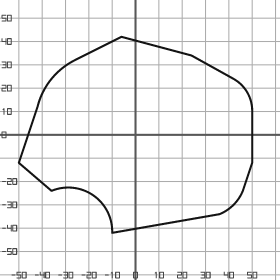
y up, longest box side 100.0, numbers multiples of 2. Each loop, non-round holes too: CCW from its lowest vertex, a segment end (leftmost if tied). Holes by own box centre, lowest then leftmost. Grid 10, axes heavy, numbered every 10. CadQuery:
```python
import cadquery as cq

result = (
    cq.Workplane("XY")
    .moveTo(-10.0, -42.0)
    .lineTo(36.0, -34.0)
    .threePointArc((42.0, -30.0), (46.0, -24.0))
    .lineTo(50.0, -12.0)
    .lineTo(50.0, 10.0)
    .threePointArc((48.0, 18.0), (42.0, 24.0))
    .lineTo(24.0, 34.0)
    .lineTo(-6.0, 42.0)
    .lineTo(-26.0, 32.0)
    .threePointArc((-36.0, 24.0), (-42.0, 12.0))
    .lineTo(-50.0, -12.0)
    .lineTo(-36.0, -24.0)
    .threePointArc((-18.0, -26.0), (-10.0, -42.0))
    .close()
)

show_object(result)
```